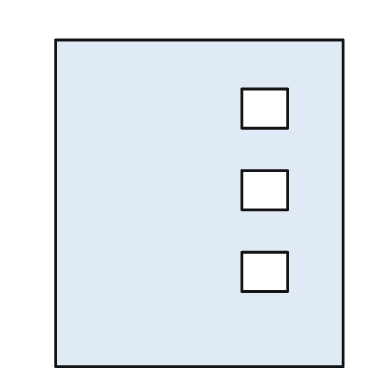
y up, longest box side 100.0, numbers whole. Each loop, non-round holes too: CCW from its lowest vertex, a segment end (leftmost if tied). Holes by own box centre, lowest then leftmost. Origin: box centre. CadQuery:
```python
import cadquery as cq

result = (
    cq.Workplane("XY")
    .moveTo(-44.0, -50.0)
    .lineTo(44.0, -50.0)
    .lineTo(44.0, 50.0)
    .lineTo(-44.0, 50.0)
    .close()
    .moveTo(13.0, -27.0)
    .lineTo(27.0, -27.0)
    .lineTo(27.0, -15.0)
    .lineTo(13.0, -15.0)
    .close()
    .moveTo(13.0, -2.0)
    .lineTo(27.0, -2.0)
    .lineTo(27.0, 10.0)
    .lineTo(13.0, 10.0)
    .close()
    .moveTo(13.0, 23.0)
    .lineTo(27.0, 23.0)
    .lineTo(27.0, 35.0)
    .lineTo(13.0, 35.0)
    .close()
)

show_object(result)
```